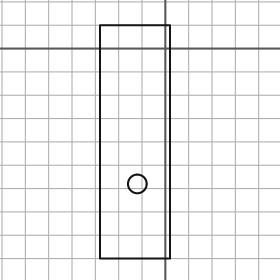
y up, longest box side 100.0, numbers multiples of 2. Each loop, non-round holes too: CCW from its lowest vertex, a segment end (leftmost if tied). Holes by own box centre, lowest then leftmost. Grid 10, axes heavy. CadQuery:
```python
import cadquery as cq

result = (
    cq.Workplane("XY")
    .moveTo(-28.0, -90.0)
    .lineTo(2.0, -90.0)
    .lineTo(2.0, 10.0)
    .lineTo(-28.0, 10.0)
    .close()
    .moveTo(-12.0, -58.0)
    .circle(4.0)
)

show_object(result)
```